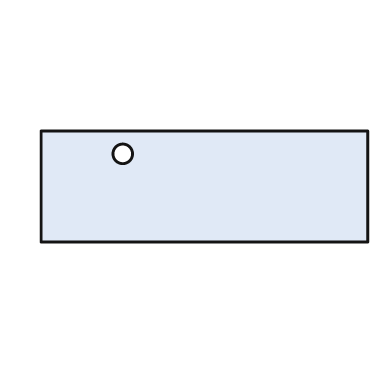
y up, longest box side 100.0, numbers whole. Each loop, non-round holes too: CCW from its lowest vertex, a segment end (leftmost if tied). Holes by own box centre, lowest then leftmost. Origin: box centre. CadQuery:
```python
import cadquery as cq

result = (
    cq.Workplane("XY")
    .moveTo(-50.0, -17.0)
    .lineTo(50.0, -17.0)
    .lineTo(50.0, 17.0)
    .lineTo(-50.0, 17.0)
    .close()
    .moveTo(-25.0, 10.0)
    .circle(3.0)
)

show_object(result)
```